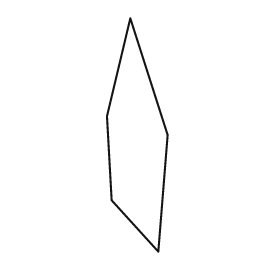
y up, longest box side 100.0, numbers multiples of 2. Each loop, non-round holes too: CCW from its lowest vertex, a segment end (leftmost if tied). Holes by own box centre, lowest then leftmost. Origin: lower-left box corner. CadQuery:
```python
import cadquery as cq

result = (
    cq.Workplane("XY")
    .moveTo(22.0, 0.0)
    .lineTo(26.0, 50.0)
    .lineTo(10.0, 100.0)
    .lineTo(0.0, 58.0)
    .lineTo(2.0, 22.0)
    .close()
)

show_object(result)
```